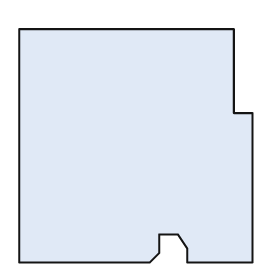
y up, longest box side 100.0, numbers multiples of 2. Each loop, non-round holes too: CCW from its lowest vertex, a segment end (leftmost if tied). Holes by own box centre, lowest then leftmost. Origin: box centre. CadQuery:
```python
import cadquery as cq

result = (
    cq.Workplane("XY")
    .moveTo(-50.0, -50.0)
    .lineTo(6.0, -50.0)
    .lineTo(10.0, -46.0)
    .lineTo(10.0, -38.0)
    .lineTo(18.0, -38.0)
    .lineTo(22.0, -44.0)
    .lineTo(22.0, -50.0)
    .lineTo(50.0, -50.0)
    .lineTo(50.0, 14.0)
    .lineTo(42.0, 14.0)
    .lineTo(42.0, 50.0)
    .lineTo(-50.0, 50.0)
    .close()
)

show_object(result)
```